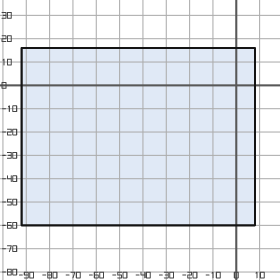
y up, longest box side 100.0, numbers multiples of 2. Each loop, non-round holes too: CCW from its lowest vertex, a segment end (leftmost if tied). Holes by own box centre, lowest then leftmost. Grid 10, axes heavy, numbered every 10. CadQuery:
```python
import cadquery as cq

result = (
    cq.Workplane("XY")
    .moveTo(-92.0, -60.0)
    .lineTo(8.0, -60.0)
    .lineTo(8.0, 16.0)
    .lineTo(-92.0, 16.0)
    .close()
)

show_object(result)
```